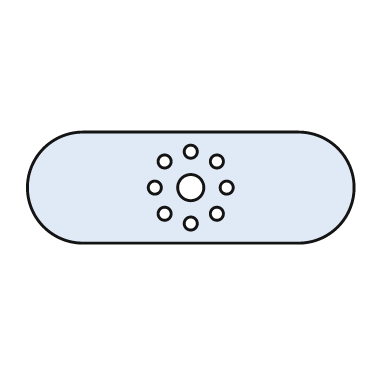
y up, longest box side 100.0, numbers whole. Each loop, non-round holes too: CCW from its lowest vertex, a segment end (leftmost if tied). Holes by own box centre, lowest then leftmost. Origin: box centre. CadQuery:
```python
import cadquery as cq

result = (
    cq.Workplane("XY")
    .moveTo(-33.0, -17.0)
    .lineTo(33.0, -17.0)
    .threePointArc((50.0, 0.0), (33.0, 17.0))
    .lineTo(-33.0, 17.0)
    .threePointArc((-50.0, 0.0), (-33.0, -17.0))
    .close()
    .moveTo(0.0, -11.0)
    .circle(2.0)
    .moveTo(-8.0, -8.0)
    .circle(2.0)
    .moveTo(8.0, -8.0)
    .circle(2.0)
    .moveTo(-11.0, 0.0)
    .circle(2.0)
    .moveTo(0.0, 0.0)
    .circle(4.0)
    .moveTo(11.0, 0.0)
    .circle(2.0)
    .moveTo(-8.0, 8.0)
    .circle(2.0)
    .moveTo(8.0, 8.0)
    .circle(2.0)
    .moveTo(0.0, 11.0)
    .circle(2.0)
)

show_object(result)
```